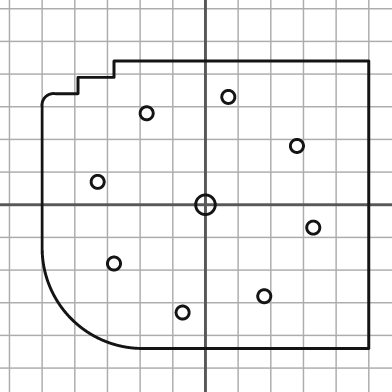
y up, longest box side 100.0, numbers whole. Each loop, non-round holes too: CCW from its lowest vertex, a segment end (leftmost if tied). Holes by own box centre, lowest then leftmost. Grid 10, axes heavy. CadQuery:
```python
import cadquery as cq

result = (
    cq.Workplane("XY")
    .moveTo(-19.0, -44.0)
    .lineTo(50.0, -44.0)
    .lineTo(50.0, 44.0)
    .lineTo(-28.0, 44.0)
    .lineTo(-28.0, 39.0)
    .lineTo(-39.0, 39.0)
    .lineTo(-39.0, 34.0)
    .lineTo(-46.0, 34.0)
    .threePointArc((-49.0, 33.0), (-50.0, 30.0))
    .lineTo(-50.0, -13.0)
    .threePointArc((-41.0, -35.0), (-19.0, -44.0))
    .close()
    .moveTo(-7.0, -33.0)
    .circle(2.0)
    .moveTo(18.0, -28.0)
    .circle(2.0)
    .moveTo(-28.0, -18.0)
    .circle(2.0)
    .moveTo(33.0, -7.0)
    .circle(2.0)
    .moveTo(0.0, 0.0)
    .circle(3.0)
    .moveTo(-33.0, 7.0)
    .circle(2.0)
    .moveTo(28.0, 18.0)
    .circle(2.0)
    .moveTo(-18.0, 28.0)
    .circle(2.0)
    .moveTo(7.0, 33.0)
    .circle(2.0)
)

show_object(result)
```